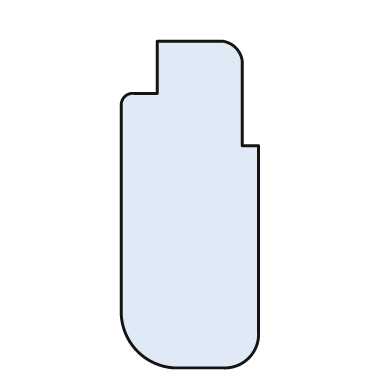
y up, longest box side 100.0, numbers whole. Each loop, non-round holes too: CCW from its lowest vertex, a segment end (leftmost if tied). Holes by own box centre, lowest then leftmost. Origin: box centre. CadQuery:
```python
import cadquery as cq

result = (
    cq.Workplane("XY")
    .moveTo(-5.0, -50.0)
    .lineTo(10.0, -50.0)
    .threePointArc((18.0, -47.0), (21.0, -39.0))
    .lineTo(21.0, 18.0)
    .lineTo(16.0, 18.0)
    .lineTo(16.0, 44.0)
    .threePointArc((14.0, 48.0), (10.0, 50.0))
    .lineTo(-10.0, 50.0)
    .lineTo(-10.0, 34.0)
    .lineTo(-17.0, 34.0)
    .threePointArc((-20.0, 33.0), (-21.0, 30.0))
    .lineTo(-21.0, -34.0)
    .threePointArc((-16.0, -45.0), (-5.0, -50.0))
    .close()
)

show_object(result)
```